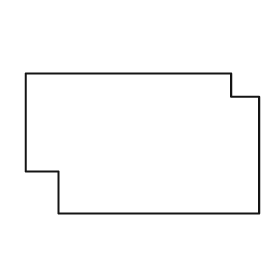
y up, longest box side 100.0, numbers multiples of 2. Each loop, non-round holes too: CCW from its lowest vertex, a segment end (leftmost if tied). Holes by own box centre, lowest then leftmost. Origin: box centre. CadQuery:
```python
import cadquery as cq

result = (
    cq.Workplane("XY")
    .moveTo(-36.0, -30.0)
    .lineTo(50.0, -30.0)
    .lineTo(50.0, 20.0)
    .lineTo(38.0, 20.0)
    .lineTo(38.0, 30.0)
    .lineTo(-50.0, 30.0)
    .lineTo(-50.0, -12.0)
    .lineTo(-36.0, -12.0)
    .close()
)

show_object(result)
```